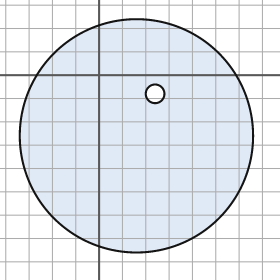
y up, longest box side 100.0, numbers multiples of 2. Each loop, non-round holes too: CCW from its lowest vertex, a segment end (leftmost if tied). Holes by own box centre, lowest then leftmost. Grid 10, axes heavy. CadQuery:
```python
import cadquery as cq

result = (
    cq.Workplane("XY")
    .moveTo(16.0, -26.0)
    .circle(50.0)
    .moveTo(24.0, -8.0)
    .circle(4.0)
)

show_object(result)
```